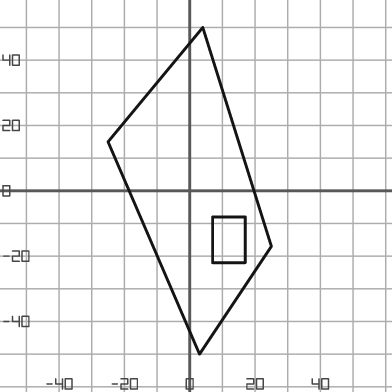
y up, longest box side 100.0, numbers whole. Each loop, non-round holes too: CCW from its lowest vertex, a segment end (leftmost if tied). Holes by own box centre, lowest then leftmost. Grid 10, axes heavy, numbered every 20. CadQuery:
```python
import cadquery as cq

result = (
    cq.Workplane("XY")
    .moveTo(3.0, -50.0)
    .lineTo(25.0, -17.0)
    .lineTo(4.0, 50.0)
    .lineTo(-25.0, 15.0)
    .close()
    .moveTo(7.0, -22.0)
    .lineTo(17.0, -22.0)
    .lineTo(17.0, -8.0)
    .lineTo(7.0, -8.0)
    .close()
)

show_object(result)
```